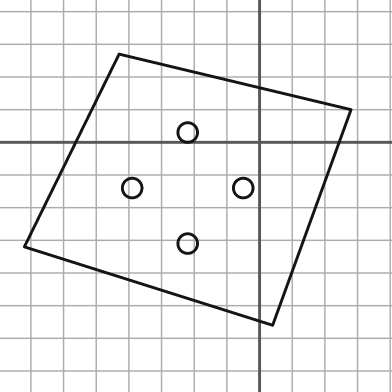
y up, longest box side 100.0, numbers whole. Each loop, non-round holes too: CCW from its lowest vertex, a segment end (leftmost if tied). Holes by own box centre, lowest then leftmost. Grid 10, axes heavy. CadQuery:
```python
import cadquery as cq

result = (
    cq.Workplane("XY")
    .moveTo(4.0, -56.0)
    .lineTo(28.0, 10.0)
    .lineTo(-43.0, 27.0)
    .lineTo(-72.0, -32.0)
    .close()
    .moveTo(-22.0, -31.0)
    .circle(3.0)
    .moveTo(-39.0, -14.0)
    .circle(3.0)
    .moveTo(-5.0, -14.0)
    .circle(3.0)
    .moveTo(-22.0, 3.0)
    .circle(3.0)
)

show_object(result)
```